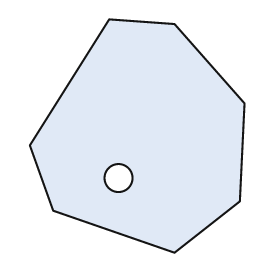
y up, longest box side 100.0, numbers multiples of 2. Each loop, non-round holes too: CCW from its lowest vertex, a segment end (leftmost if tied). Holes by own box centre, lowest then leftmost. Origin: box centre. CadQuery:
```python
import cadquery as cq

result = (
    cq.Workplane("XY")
    .moveTo(16.0, -50.0)
    .lineTo(44.0, -28.0)
    .lineTo(46.0, 14.0)
    .lineTo(16.0, 48.0)
    .lineTo(-12.0, 50.0)
    .lineTo(-46.0, -4.0)
    .lineTo(-36.0, -32.0)
    .close()
    .moveTo(-8.0, -18.0)
    .circle(6.0)
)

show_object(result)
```